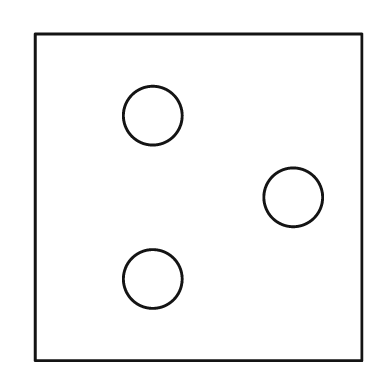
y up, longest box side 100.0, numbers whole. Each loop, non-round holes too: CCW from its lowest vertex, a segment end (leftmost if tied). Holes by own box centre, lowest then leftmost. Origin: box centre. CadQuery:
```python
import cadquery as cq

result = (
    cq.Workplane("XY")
    .moveTo(-50.0, -50.0)
    .lineTo(50.0, -50.0)
    .lineTo(50.0, 50.0)
    .lineTo(-50.0, 50.0)
    .close()
    .moveTo(-14.0, -25.0)
    .circle(9.0)
    .moveTo(29.0, 0.0)
    .circle(9.0)
    .moveTo(-14.0, 25.0)
    .circle(9.0)
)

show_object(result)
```